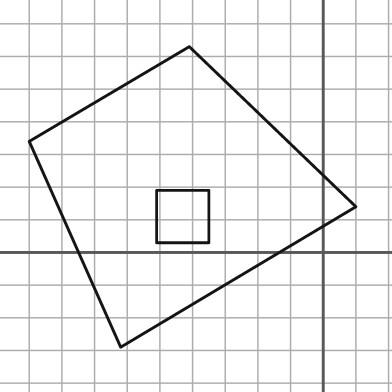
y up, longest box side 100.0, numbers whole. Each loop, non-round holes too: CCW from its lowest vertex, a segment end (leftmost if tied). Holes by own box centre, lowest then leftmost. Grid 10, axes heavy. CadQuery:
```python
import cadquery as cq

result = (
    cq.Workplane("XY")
    .moveTo(-62.0, -29.0)
    .lineTo(10.0, 14.0)
    .lineTo(-41.0, 63.0)
    .lineTo(-90.0, 34.0)
    .close()
    .moveTo(-51.0, 3.0)
    .lineTo(-35.0, 3.0)
    .lineTo(-35.0, 19.0)
    .lineTo(-51.0, 19.0)
    .close()
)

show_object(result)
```